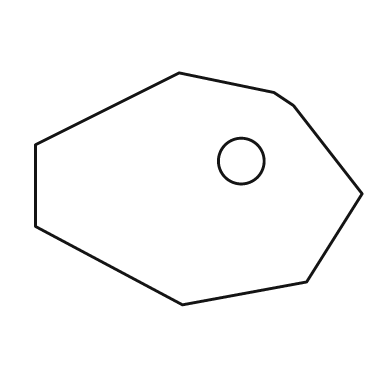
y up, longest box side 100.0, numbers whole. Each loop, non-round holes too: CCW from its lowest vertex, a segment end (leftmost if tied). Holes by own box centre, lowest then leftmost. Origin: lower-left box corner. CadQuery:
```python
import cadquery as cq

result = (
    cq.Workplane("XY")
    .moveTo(45.0, 0.0)
    .lineTo(83.0, 7.0)
    .lineTo(100.0, 34.0)
    .lineTo(79.0, 61.0)
    .lineTo(73.0, 65.0)
    .lineTo(44.0, 71.0)
    .lineTo(0.0, 49.0)
    .lineTo(0.0, 24.0)
    .close()
    .moveTo(63.0, 44.0)
    .circle(7.0)
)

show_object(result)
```